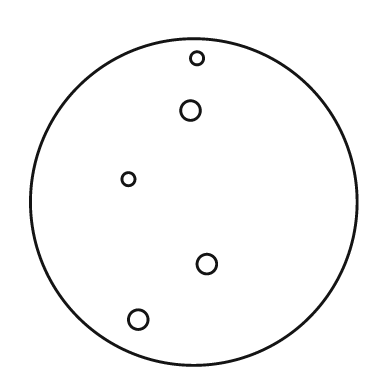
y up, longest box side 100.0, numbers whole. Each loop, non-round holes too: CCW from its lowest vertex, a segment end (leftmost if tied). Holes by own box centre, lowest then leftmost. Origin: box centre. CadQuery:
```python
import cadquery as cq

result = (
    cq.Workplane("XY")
    .moveTo(0.0, 0.0)
    .circle(50.0)
    .moveTo(-17.0, -36.0)
    .circle(3.0)
    .moveTo(4.0, -19.0)
    .circle(3.0)
    .moveTo(-20.0, 7.0)
    .circle(2.0)
    .moveTo(-1.0, 28.0)
    .circle(3.0)
    .moveTo(1.0, 44.0)
    .circle(2.0)
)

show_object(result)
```